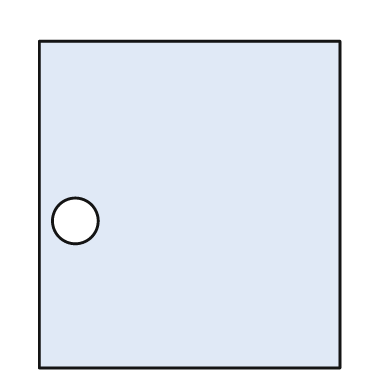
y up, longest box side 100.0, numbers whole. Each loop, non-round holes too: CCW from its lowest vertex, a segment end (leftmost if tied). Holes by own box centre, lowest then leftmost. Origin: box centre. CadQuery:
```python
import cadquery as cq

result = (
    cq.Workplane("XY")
    .moveTo(-46.0, -50.0)
    .lineTo(46.0, -50.0)
    .lineTo(46.0, 50.0)
    .lineTo(-46.0, 50.0)
    .close()
    .moveTo(-35.0, -5.0)
    .circle(7.0)
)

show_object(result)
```